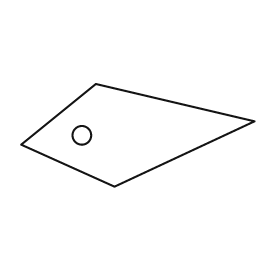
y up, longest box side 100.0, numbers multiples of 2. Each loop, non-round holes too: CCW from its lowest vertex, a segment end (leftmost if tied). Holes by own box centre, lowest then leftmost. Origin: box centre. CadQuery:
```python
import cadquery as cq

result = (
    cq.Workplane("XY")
    .moveTo(-10.0, -22.0)
    .lineTo(50.0, 6.0)
    .lineTo(-18.0, 22.0)
    .lineTo(-50.0, -4.0)
    .close()
    .moveTo(-24.0, 0.0)
    .circle(4.0)
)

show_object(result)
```